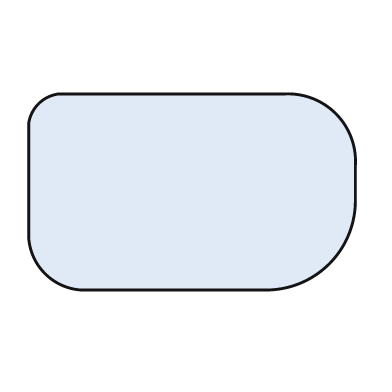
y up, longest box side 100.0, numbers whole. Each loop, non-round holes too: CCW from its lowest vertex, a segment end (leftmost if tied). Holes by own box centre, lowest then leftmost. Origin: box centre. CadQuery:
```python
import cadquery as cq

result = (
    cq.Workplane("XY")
    .moveTo(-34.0, -30.0)
    .lineTo(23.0, -30.0)
    .threePointArc((42.0, -22.0), (50.0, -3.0))
    .lineTo(50.0, 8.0)
    .threePointArc((44.0, 24.0), (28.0, 30.0))
    .lineTo(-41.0, 30.0)
    .threePointArc((-47.0, 27.0), (-50.0, 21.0))
    .lineTo(-50.0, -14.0)
    .threePointArc((-45.0, -25.0), (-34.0, -30.0))
    .close()
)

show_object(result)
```